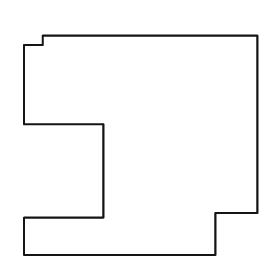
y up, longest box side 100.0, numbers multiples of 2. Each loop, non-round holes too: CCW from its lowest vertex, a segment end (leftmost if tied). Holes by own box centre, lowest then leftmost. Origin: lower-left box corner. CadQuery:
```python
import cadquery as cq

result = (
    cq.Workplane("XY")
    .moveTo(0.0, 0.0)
    .lineTo(82.0, 0.0)
    .lineTo(82.0, 18.0)
    .lineTo(100.0, 18.0)
    .lineTo(100.0, 94.0)
    .lineTo(8.0, 94.0)
    .lineTo(8.0, 90.0)
    .lineTo(0.0, 90.0)
    .lineTo(0.0, 56.0)
    .lineTo(34.0, 56.0)
    .lineTo(34.0, 16.0)
    .lineTo(0.0, 16.0)
    .close()
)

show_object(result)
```